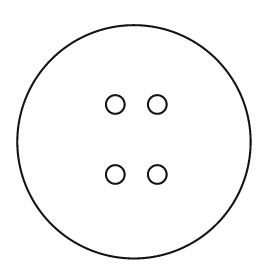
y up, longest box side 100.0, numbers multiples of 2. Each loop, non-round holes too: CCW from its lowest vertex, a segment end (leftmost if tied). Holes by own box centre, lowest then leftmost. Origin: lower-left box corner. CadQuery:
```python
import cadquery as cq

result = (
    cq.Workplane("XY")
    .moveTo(50.0, 50.0)
    .circle(50.0)
    .moveTo(42.0, 36.0)
    .circle(4.0)
    .moveTo(60.0, 36.0)
    .circle(4.0)
    .moveTo(42.0, 66.0)
    .circle(4.0)
    .moveTo(60.0, 66.0)
    .circle(4.0)
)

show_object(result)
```